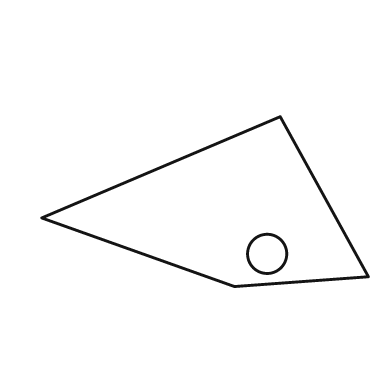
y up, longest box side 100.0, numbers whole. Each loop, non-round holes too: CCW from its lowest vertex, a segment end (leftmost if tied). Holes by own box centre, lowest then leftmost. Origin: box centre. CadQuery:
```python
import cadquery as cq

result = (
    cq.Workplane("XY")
    .moveTo(9.0, -26.0)
    .lineTo(50.0, -23.0)
    .lineTo(23.0, 26.0)
    .lineTo(-50.0, -5.0)
    .close()
    .moveTo(19.0, -16.0)
    .circle(6.0)
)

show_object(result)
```